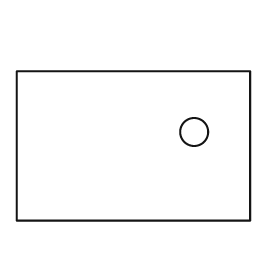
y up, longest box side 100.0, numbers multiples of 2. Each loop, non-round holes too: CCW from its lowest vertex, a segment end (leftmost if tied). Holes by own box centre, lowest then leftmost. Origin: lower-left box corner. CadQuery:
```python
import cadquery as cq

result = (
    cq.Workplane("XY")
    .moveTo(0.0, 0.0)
    .lineTo(100.0, 0.0)
    .lineTo(100.0, 64.0)
    .lineTo(0.0, 64.0)
    .close()
    .moveTo(76.0, 38.0)
    .circle(6.0)
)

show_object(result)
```